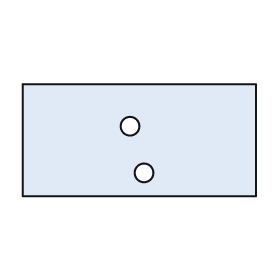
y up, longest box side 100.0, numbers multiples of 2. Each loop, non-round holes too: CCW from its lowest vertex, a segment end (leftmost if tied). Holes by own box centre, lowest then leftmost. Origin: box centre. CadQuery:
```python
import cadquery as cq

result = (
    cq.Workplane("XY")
    .moveTo(-50.0, -24.0)
    .lineTo(50.0, -24.0)
    .lineTo(50.0, 24.0)
    .lineTo(-50.0, 24.0)
    .close()
    .moveTo(2.0, -14.0)
    .circle(4.0)
    .moveTo(-4.0, 6.0)
    .circle(4.0)
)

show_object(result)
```